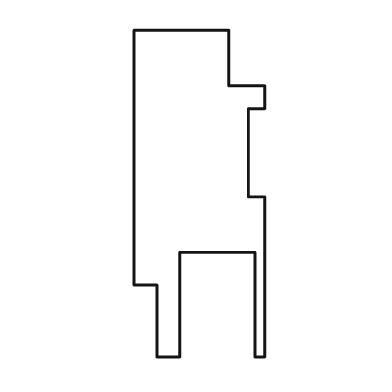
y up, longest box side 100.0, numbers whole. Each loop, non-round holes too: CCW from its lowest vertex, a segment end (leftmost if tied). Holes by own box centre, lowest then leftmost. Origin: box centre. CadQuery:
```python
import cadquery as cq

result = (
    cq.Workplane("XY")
    .moveTo(-13.0, -50.0)
    .lineTo(-6.0, -50.0)
    .lineTo(-6.0, -18.0)
    .lineTo(17.0, -18.0)
    .lineTo(17.0, -50.0)
    .lineTo(20.0, -50.0)
    .lineTo(20.0, -1.0)
    .lineTo(15.0, -1.0)
    .lineTo(15.0, 26.0)
    .lineTo(20.0, 26.0)
    .lineTo(20.0, 33.0)
    .lineTo(9.0, 33.0)
    .lineTo(9.0, 50.0)
    .lineTo(-20.0, 50.0)
    .lineTo(-20.0, -28.0)
    .lineTo(-13.0, -28.0)
    .close()
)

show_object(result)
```